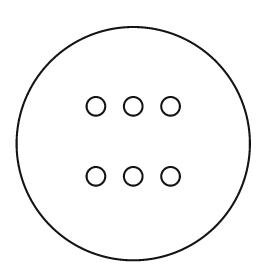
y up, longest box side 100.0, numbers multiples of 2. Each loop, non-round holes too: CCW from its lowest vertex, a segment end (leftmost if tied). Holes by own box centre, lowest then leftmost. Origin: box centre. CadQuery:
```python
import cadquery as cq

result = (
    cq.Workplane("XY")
    .moveTo(0.0, 0.0)
    .circle(50.0)
    .moveTo(-16.0, -14.0)
    .circle(4.0)
    .moveTo(0.0, -14.0)
    .circle(4.0)
    .moveTo(16.0, -14.0)
    .circle(4.0)
    .moveTo(-16.0, 16.0)
    .circle(4.0)
    .moveTo(0.0, 16.0)
    .circle(4.0)
    .moveTo(16.0, 16.0)
    .circle(4.0)
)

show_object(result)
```